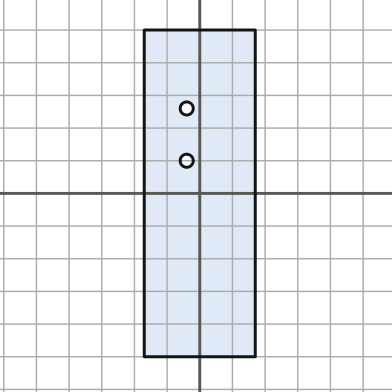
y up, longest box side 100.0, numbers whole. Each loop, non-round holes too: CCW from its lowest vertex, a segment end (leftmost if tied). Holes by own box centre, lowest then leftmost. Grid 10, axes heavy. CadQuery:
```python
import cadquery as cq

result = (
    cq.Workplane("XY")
    .moveTo(-17.0, -50.0)
    .lineTo(17.0, -50.0)
    .lineTo(17.0, 50.0)
    .lineTo(-17.0, 50.0)
    .close()
    .moveTo(-4.0, 10.0)
    .circle(2.0)
    .moveTo(-4.0, 26.0)
    .circle(2.0)
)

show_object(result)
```